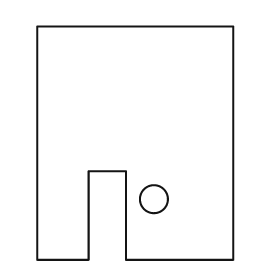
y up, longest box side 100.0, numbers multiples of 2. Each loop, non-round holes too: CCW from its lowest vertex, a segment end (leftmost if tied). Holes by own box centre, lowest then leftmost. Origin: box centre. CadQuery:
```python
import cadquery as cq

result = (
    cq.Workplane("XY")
    .moveTo(-42.0, -50.0)
    .lineTo(-20.0, -50.0)
    .lineTo(-20.0, -12.0)
    .lineTo(-4.0, -12.0)
    .lineTo(-4.0, -50.0)
    .lineTo(42.0, -50.0)
    .lineTo(42.0, 50.0)
    .lineTo(-42.0, 50.0)
    .close()
    .moveTo(8.0, -24.0)
    .circle(6.0)
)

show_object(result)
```